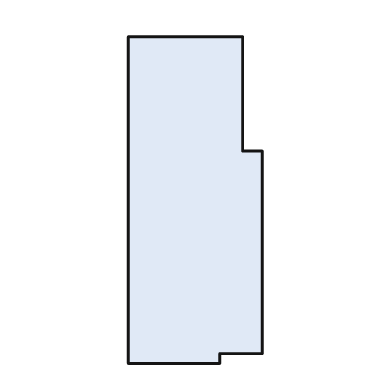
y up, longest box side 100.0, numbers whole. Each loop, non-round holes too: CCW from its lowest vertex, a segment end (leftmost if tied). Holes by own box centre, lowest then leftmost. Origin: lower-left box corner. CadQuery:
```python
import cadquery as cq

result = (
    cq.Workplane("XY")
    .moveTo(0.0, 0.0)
    .lineTo(28.0, 0.0)
    .lineTo(28.0, 3.0)
    .lineTo(41.0, 3.0)
    .lineTo(41.0, 65.0)
    .lineTo(35.0, 65.0)
    .lineTo(35.0, 100.0)
    .lineTo(0.0, 100.0)
    .close()
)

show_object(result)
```